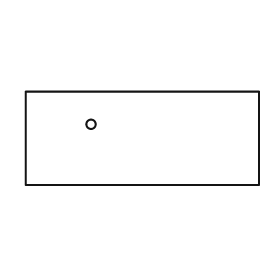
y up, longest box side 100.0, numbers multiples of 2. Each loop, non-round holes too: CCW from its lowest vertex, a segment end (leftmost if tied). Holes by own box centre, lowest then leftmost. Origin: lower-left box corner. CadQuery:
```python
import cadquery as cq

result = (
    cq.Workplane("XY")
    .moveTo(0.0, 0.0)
    .lineTo(100.0, 0.0)
    .lineTo(100.0, 40.0)
    .lineTo(0.0, 40.0)
    .close()
    .moveTo(28.0, 26.0)
    .circle(2.0)
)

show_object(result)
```